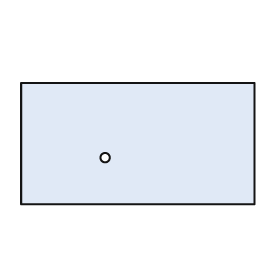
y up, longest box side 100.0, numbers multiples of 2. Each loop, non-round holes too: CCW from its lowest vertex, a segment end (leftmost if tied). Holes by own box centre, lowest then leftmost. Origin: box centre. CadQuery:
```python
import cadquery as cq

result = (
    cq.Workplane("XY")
    .moveTo(-50.0, -26.0)
    .lineTo(50.0, -26.0)
    .lineTo(50.0, 26.0)
    .lineTo(-50.0, 26.0)
    .close()
    .moveTo(-14.0, -6.0)
    .circle(2.0)
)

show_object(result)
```